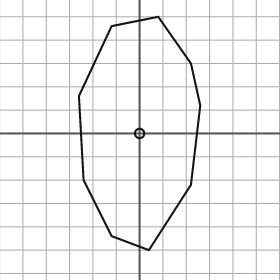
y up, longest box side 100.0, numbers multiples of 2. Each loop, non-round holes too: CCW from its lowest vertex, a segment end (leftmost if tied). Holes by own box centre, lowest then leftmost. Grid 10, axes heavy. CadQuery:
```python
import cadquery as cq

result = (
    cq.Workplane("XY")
    .moveTo(4.0, -50.0)
    .lineTo(22.0, -22.0)
    .lineTo(26.0, 12.0)
    .lineTo(22.0, 30.0)
    .lineTo(8.0, 50.0)
    .lineTo(-12.0, 46.0)
    .lineTo(-26.0, 16.0)
    .lineTo(-24.0, -20.0)
    .lineTo(-12.0, -44.0)
    .close()
    .moveTo(0.0, 0.0)
    .circle(2.0)
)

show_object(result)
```